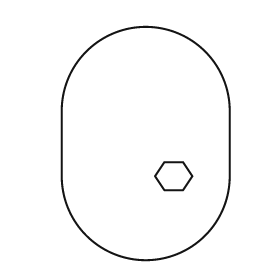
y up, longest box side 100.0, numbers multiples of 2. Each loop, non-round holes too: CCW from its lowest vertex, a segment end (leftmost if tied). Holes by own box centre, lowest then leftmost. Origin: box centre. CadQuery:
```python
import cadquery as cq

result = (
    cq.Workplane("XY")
    .moveTo(-36.0, -14.0)
    .threePointArc((0.0, -50.0), (36.0, -14.0))
    .lineTo(36.0, 14.0)
    .threePointArc((0.0, 50.0), (-36.0, 14.0))
    .close()
    .moveTo(8.0, -20.0)
    .lineTo(16.0, -20.0)
    .lineTo(20.0, -14.0)
    .lineTo(16.0, -8.0)
    .lineTo(8.0, -8.0)
    .lineTo(4.0, -14.0)
    .close()
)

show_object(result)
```